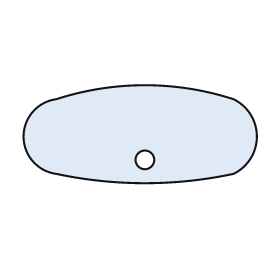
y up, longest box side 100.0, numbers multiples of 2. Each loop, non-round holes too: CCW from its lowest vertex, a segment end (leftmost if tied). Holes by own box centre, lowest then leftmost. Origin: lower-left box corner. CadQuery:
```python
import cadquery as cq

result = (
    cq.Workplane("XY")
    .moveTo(14.0, 4.0)
    .threePointArc((52.0, 0.0), (90.0, 4.0))
    .threePointArc((100.0, 20.0), (90.0, 36.0))
    .threePointArc((52.0, 42.0), (14.0, 36.0))
    .threePointArc((0.0, 20.0), (14.0, 4.0))
    .close()
    .moveTo(52.0, 10.0)
    .circle(4.0)
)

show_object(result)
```